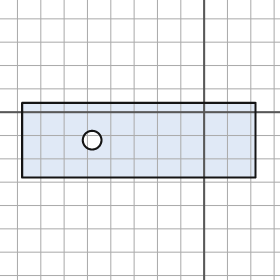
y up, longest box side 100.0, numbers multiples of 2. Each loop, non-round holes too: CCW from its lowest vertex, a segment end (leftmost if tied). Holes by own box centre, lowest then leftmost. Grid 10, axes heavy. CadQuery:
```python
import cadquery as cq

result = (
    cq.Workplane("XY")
    .moveTo(-78.0, -28.0)
    .lineTo(22.0, -28.0)
    .lineTo(22.0, 4.0)
    .lineTo(-78.0, 4.0)
    .close()
    .moveTo(-48.0, -12.0)
    .circle(4.0)
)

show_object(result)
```